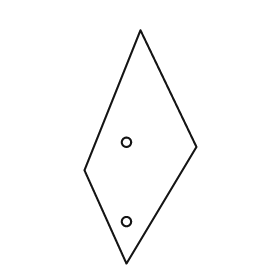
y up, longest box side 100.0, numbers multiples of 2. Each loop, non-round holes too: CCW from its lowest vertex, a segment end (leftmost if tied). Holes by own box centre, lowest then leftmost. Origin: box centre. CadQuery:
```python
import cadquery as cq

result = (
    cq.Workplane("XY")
    .moveTo(-6.0, -50.0)
    .lineTo(24.0, 0.0)
    .lineTo(0.0, 50.0)
    .lineTo(-24.0, -10.0)
    .close()
    .moveTo(-6.0, -32.0)
    .circle(2.0)
    .moveTo(-6.0, 2.0)
    .circle(2.0)
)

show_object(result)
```